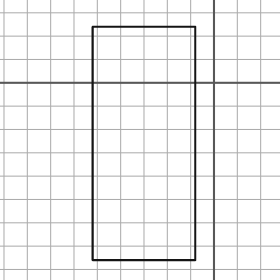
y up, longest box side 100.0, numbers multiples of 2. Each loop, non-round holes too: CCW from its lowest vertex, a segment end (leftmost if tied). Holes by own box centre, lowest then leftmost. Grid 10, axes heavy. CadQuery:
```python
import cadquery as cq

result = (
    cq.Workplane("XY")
    .moveTo(-52.0, -76.0)
    .lineTo(-8.0, -76.0)
    .lineTo(-8.0, 24.0)
    .lineTo(-52.0, 24.0)
    .close()
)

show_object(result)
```